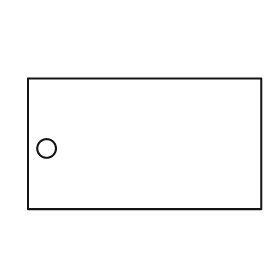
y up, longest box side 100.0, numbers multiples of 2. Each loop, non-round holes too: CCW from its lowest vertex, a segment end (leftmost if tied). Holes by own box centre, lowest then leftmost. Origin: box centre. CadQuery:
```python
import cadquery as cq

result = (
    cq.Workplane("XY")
    .moveTo(-50.0, -28.0)
    .lineTo(50.0, -28.0)
    .lineTo(50.0, 28.0)
    .lineTo(-50.0, 28.0)
    .close()
    .moveTo(-42.0, -2.0)
    .circle(4.0)
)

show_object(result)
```